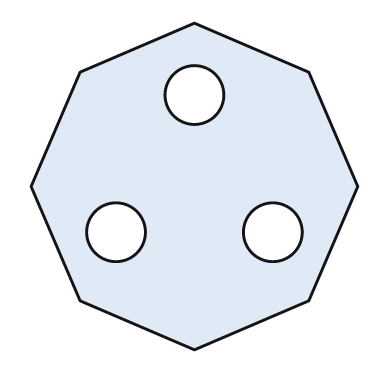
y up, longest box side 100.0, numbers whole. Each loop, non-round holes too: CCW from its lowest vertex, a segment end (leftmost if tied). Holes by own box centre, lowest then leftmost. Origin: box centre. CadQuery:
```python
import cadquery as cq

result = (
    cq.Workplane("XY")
    .moveTo(0.0, -50.0)
    .lineTo(35.0, -35.0)
    .lineTo(50.0, 0.0)
    .lineTo(35.0, 35.0)
    .lineTo(0.0, 50.0)
    .lineTo(-35.0, 35.0)
    .lineTo(-50.0, 0.0)
    .lineTo(-35.0, -35.0)
    .close()
    .moveTo(-24.0, -14.0)
    .circle(9.0)
    .moveTo(24.0, -14.0)
    .circle(9.0)
    .moveTo(0.0, 28.0)
    .circle(9.0)
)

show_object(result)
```